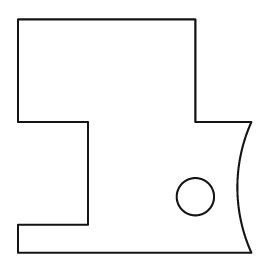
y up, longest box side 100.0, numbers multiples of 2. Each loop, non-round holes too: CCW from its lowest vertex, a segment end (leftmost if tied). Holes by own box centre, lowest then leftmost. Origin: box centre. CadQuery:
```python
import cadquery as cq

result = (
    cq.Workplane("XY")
    .moveTo(-50.0, -50.0)
    .lineTo(50.0, -50.0)
    .threePointArc((44.0, -22.0), (50.0, 6.0))
    .lineTo(26.0, 6.0)
    .lineTo(26.0, 50.0)
    .lineTo(-50.0, 50.0)
    .lineTo(-50.0, 6.0)
    .lineTo(-20.0, 6.0)
    .lineTo(-20.0, -38.0)
    .lineTo(-50.0, -38.0)
    .close()
    .moveTo(26.0, -26.0)
    .circle(8.0)
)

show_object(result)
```